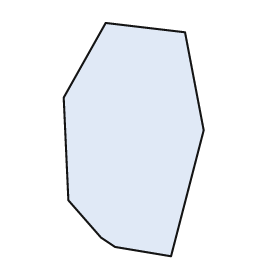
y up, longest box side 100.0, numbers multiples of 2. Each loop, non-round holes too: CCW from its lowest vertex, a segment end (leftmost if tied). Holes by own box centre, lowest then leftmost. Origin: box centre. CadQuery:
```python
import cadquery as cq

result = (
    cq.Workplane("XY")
    .moveTo(16.0, -50.0)
    .lineTo(30.0, 4.0)
    .lineTo(22.0, 46.0)
    .lineTo(-12.0, 50.0)
    .lineTo(-30.0, 18.0)
    .lineTo(-28.0, -26.0)
    .lineTo(-14.0, -42.0)
    .lineTo(-8.0, -46.0)
    .close()
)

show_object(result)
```